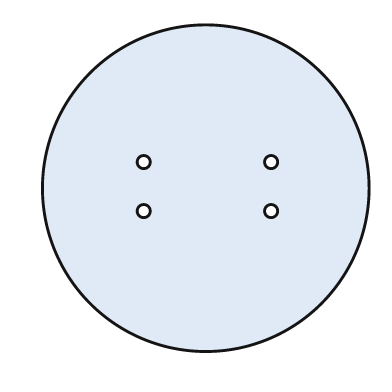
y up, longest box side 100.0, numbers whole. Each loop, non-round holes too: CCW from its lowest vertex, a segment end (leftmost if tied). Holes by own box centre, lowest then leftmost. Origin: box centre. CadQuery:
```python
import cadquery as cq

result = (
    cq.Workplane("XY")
    .moveTo(0.0, 0.0)
    .circle(50.0)
    .moveTo(-19.0, -7.0)
    .circle(2.0)
    .moveTo(20.0, -7.0)
    .circle(2.0)
    .moveTo(-19.0, 8.0)
    .circle(2.0)
    .moveTo(20.0, 8.0)
    .circle(2.0)
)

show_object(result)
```